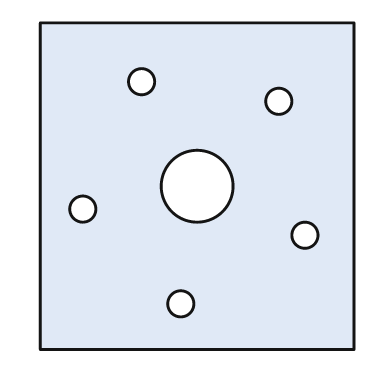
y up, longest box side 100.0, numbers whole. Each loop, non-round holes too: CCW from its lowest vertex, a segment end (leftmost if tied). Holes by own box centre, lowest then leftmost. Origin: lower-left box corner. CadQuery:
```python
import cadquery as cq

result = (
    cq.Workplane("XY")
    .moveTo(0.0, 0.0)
    .lineTo(96.0, 0.0)
    .lineTo(96.0, 100.0)
    .lineTo(0.0, 100.0)
    .close()
    .moveTo(43.0, 14.0)
    .circle(4.0)
    .moveTo(81.0, 35.0)
    .circle(4.0)
    .moveTo(13.0, 43.0)
    .circle(4.0)
    .moveTo(48.0, 50.0)
    .circle(11.0)
    .moveTo(73.0, 76.0)
    .circle(4.0)
    .moveTo(31.0, 82.0)
    .circle(4.0)
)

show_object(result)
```